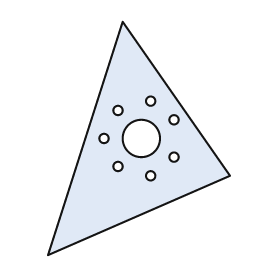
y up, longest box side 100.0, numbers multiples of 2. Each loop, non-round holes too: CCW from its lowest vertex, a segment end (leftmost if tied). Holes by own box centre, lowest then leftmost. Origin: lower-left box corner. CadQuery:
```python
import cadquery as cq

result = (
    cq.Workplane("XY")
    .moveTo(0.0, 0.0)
    .lineTo(78.0, 34.0)
    .lineTo(32.0, 100.0)
    .close()
    .moveTo(44.0, 34.0)
    .circle(2.0)
    .moveTo(30.0, 38.0)
    .circle(2.0)
    .moveTo(54.0, 42.0)
    .circle(2.0)
    .moveTo(24.0, 50.0)
    .circle(2.0)
    .moveTo(40.0, 50.0)
    .circle(8.0)
    .moveTo(54.0, 58.0)
    .circle(2.0)
    .moveTo(30.0, 62.0)
    .circle(2.0)
    .moveTo(44.0, 66.0)
    .circle(2.0)
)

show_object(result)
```